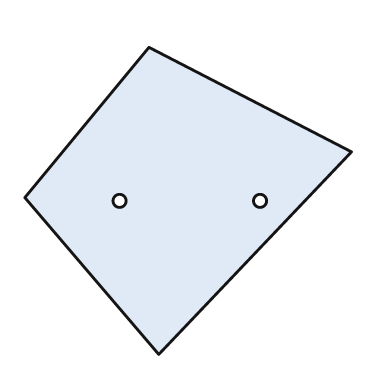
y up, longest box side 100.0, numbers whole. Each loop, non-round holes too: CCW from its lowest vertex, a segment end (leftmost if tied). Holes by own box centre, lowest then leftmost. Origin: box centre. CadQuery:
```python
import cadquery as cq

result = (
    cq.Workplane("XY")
    .moveTo(-9.0, -47.0)
    .lineTo(50.0, 15.0)
    .lineTo(-12.0, 47.0)
    .lineTo(-50.0, 1.0)
    .close()
    .moveTo(-21.0, 0.0)
    .circle(2.0)
    .moveTo(22.0, 0.0)
    .circle(2.0)
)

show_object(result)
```